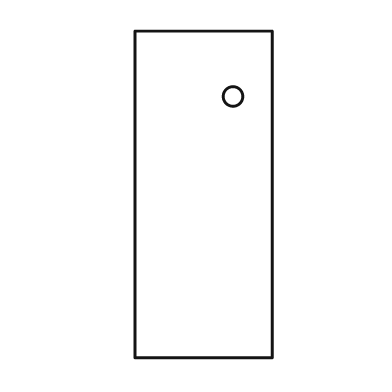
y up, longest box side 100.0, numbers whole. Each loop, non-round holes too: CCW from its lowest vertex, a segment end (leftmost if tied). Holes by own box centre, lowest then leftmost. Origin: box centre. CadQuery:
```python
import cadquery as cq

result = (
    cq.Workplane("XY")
    .moveTo(-21.0, -50.0)
    .lineTo(21.0, -50.0)
    .lineTo(21.0, 50.0)
    .lineTo(-21.0, 50.0)
    .close()
    .moveTo(9.0, 30.0)
    .circle(3.0)
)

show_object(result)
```